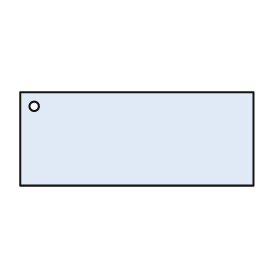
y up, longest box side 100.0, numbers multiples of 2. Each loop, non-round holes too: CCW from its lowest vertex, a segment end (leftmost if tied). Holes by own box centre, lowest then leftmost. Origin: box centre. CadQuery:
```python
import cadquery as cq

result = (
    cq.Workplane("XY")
    .moveTo(-50.0, -20.0)
    .lineTo(50.0, -20.0)
    .lineTo(50.0, 20.0)
    .lineTo(-50.0, 20.0)
    .close()
    .moveTo(-44.0, 14.0)
    .circle(2.0)
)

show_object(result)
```